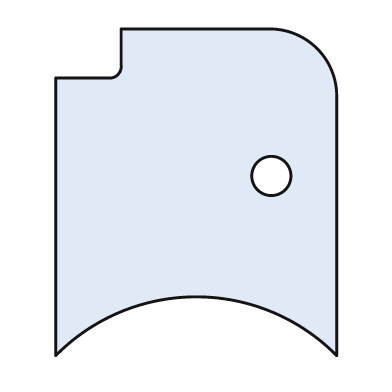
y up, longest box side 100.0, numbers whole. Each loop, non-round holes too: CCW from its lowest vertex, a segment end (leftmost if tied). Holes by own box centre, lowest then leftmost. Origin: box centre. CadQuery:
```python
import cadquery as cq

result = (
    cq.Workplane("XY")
    .moveTo(-43.0, -50.0)
    .threePointArc((0.0, -32.0), (43.0, -50.0))
    .lineTo(43.0, 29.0)
    .threePointArc((37.0, 44.0), (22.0, 50.0))
    .lineTo(-23.0, 50.0)
    .lineTo(-23.0, 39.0)
    .threePointArc((-24.0, 36.0), (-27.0, 35.0))
    .lineTo(-43.0, 35.0)
    .close()
    .moveTo(23.0, 5.0)
    .circle(6.0)
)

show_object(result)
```